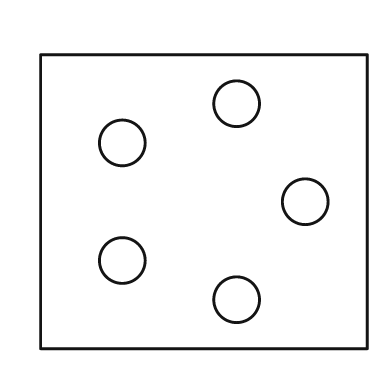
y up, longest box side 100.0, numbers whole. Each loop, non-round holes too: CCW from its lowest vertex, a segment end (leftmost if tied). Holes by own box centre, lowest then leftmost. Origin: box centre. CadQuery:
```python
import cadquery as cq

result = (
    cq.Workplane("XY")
    .moveTo(-50.0, -45.0)
    .lineTo(50.0, -45.0)
    .lineTo(50.0, 45.0)
    .lineTo(-50.0, 45.0)
    .close()
    .moveTo(10.0, -30.0)
    .circle(7.0)
    .moveTo(-25.0, -18.0)
    .circle(7.0)
    .moveTo(31.0, 0.0)
    .circle(7.0)
    .moveTo(-25.0, 18.0)
    .circle(7.0)
    .moveTo(10.0, 30.0)
    .circle(7.0)
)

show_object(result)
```